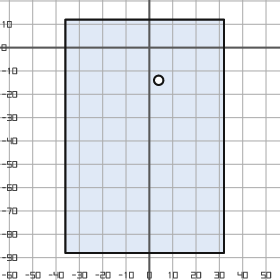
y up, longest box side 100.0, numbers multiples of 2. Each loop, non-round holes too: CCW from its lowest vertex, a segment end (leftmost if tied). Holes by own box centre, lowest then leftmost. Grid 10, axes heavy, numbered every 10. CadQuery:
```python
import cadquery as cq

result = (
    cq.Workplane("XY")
    .moveTo(-36.0, -88.0)
    .lineTo(32.0, -88.0)
    .lineTo(32.0, 12.0)
    .lineTo(-36.0, 12.0)
    .close()
    .moveTo(4.0, -14.0)
    .circle(2.0)
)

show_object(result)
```